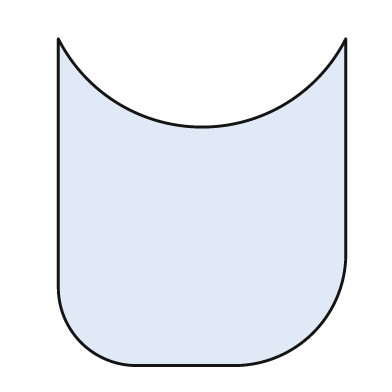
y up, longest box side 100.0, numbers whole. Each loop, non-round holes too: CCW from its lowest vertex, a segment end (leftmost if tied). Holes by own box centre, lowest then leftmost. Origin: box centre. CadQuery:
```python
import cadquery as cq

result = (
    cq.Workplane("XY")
    .moveTo(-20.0, -50.0)
    .lineTo(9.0, -50.0)
    .threePointArc((34.0, -40.0), (44.0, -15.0))
    .lineTo(44.0, 50.0)
    .threePointArc((0.0, 23.0), (-44.0, 50.0))
    .lineTo(-44.0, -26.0)
    .threePointArc((-37.0, -43.0), (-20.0, -50.0))
    .close()
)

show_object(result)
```